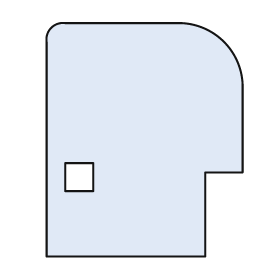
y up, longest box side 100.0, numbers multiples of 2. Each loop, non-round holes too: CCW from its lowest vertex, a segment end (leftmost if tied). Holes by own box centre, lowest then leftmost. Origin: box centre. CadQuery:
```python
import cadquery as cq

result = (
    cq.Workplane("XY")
    .moveTo(-42.0, -50.0)
    .lineTo(26.0, -50.0)
    .lineTo(26.0, -14.0)
    .lineTo(42.0, -14.0)
    .lineTo(42.0, 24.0)
    .threePointArc((34.0, 42.0), (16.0, 50.0))
    .lineTo(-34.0, 50.0)
    .threePointArc((-40.0, 48.0), (-42.0, 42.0))
    .close()
    .moveTo(-34.0, -22.0)
    .lineTo(-22.0, -22.0)
    .lineTo(-22.0, -10.0)
    .lineTo(-34.0, -10.0)
    .close()
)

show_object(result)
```